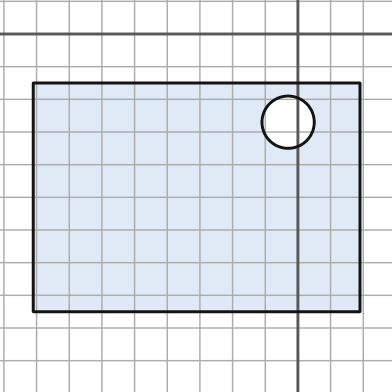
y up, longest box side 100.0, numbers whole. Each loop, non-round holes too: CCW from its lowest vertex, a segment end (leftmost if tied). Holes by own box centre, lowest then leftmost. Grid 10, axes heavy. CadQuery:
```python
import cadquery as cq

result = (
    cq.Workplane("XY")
    .moveTo(-81.0, -85.0)
    .lineTo(19.0, -85.0)
    .lineTo(19.0, -15.0)
    .lineTo(-81.0, -15.0)
    .close()
    .moveTo(-3.0, -27.0)
    .circle(8.0)
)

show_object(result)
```